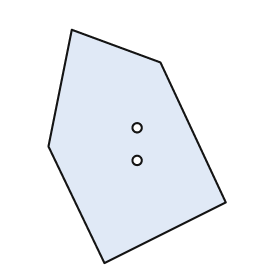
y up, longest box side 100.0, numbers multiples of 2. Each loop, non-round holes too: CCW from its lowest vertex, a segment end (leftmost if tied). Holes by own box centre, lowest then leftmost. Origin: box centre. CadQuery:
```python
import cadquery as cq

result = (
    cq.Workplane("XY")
    .moveTo(-14.0, -50.0)
    .lineTo(38.0, -24.0)
    .lineTo(10.0, 36.0)
    .lineTo(-28.0, 50.0)
    .lineTo(-38.0, 0.0)
    .close()
    .moveTo(0.0, -6.0)
    .circle(2.0)
    .moveTo(0.0, 8.0)
    .circle(2.0)
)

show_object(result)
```